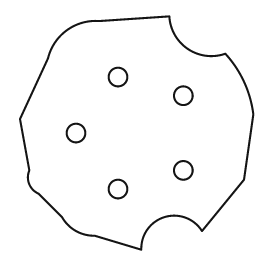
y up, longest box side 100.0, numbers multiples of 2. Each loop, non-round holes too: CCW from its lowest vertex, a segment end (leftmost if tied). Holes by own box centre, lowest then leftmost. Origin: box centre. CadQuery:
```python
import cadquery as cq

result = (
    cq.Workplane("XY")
    .moveTo(2.0, -50.0)
    .threePointArc((12.0, -36.0), (28.0, -42.0))
    .lineTo(46.0, -20.0)
    .lineTo(50.0, 8.0)
    .threePointArc((46.0, 22.0), (38.0, 34.0))
    .threePointArc((22.0, 36.0), (14.0, 50.0))
    .lineTo(-16.0, 48.0)
    .threePointArc((-30.0, 44.0), (-38.0, 32.0))
    .lineTo(-50.0, 6.0)
    .lineTo(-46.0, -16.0)
    .threePointArc((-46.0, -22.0), (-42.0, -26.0))
    .lineTo(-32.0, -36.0)
    .threePointArc((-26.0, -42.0), (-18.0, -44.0))
    .close()
    .moveTo(-8.0, -24.0)
    .circle(4.0)
    .moveTo(20.0, -16.0)
    .circle(4.0)
    .moveTo(-26.0, 0.0)
    .circle(4.0)
    .moveTo(20.0, 16.0)
    .circle(4.0)
    .moveTo(-8.0, 24.0)
    .circle(4.0)
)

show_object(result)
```